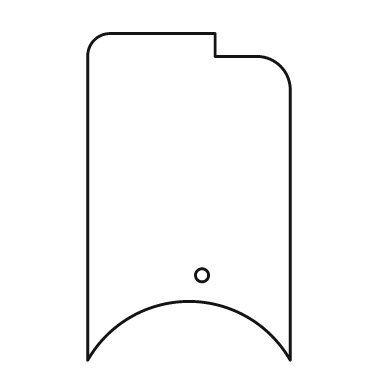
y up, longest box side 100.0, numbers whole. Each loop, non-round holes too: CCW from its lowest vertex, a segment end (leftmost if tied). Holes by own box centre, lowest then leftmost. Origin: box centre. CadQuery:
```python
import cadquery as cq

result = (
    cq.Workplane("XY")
    .moveTo(-31.0, -50.0)
    .threePointArc((0.0, -32.0), (31.0, -50.0))
    .lineTo(31.0, 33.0)
    .threePointArc((28.0, 40.0), (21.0, 43.0))
    .lineTo(8.0, 43.0)
    .lineTo(8.0, 50.0)
    .lineTo(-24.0, 50.0)
    .threePointArc((-29.0, 48.0), (-31.0, 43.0))
    .close()
    .moveTo(4.0, -24.0)
    .circle(2.0)
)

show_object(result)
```